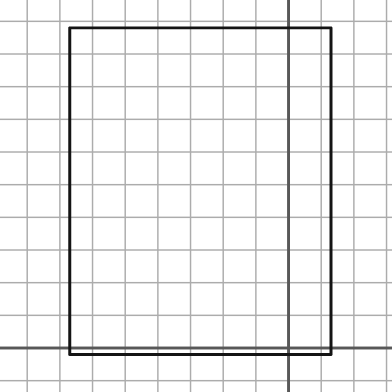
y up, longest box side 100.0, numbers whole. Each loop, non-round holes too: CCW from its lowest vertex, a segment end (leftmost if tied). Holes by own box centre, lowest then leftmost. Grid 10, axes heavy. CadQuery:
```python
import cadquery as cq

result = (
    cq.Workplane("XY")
    .moveTo(-67.0, -2.0)
    .lineTo(13.0, -2.0)
    .lineTo(13.0, 98.0)
    .lineTo(-67.0, 98.0)
    .close()
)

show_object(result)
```